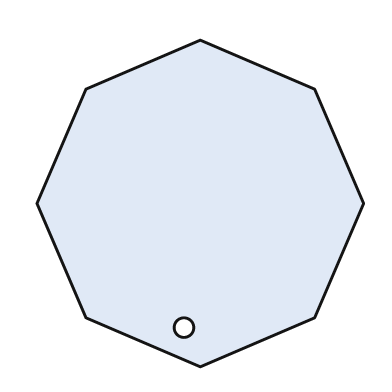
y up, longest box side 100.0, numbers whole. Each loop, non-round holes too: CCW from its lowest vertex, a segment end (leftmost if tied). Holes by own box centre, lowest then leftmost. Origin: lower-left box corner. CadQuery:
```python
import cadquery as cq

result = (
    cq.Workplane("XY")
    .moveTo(50.0, 0.0)
    .lineTo(85.0, 15.0)
    .lineTo(100.0, 50.0)
    .lineTo(85.0, 85.0)
    .lineTo(50.0, 100.0)
    .lineTo(15.0, 85.0)
    .lineTo(0.0, 50.0)
    .lineTo(15.0, 15.0)
    .close()
    .moveTo(45.0, 12.0)
    .circle(3.0)
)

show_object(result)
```